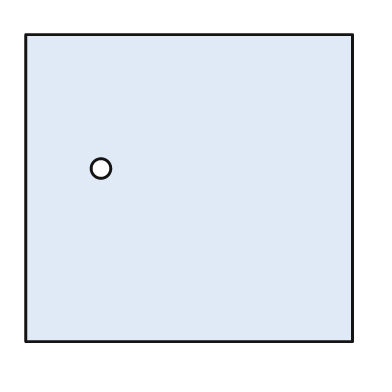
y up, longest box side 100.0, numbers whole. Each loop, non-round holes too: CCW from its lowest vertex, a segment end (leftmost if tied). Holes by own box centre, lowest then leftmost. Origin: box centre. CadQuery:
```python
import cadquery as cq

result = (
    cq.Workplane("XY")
    .moveTo(-50.0, -47.0)
    .lineTo(50.0, -47.0)
    .lineTo(50.0, 47.0)
    .lineTo(-50.0, 47.0)
    .close()
    .moveTo(-27.0, 6.0)
    .circle(3.0)
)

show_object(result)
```